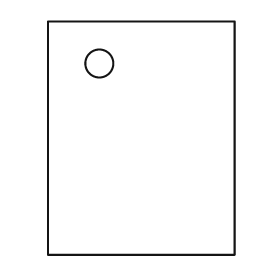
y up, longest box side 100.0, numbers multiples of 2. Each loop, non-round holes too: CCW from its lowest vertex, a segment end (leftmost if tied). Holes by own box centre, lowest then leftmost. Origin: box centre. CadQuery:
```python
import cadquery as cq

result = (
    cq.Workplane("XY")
    .moveTo(-40.0, -50.0)
    .lineTo(40.0, -50.0)
    .lineTo(40.0, 50.0)
    .lineTo(-40.0, 50.0)
    .close()
    .moveTo(-18.0, 32.0)
    .circle(6.0)
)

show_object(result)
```